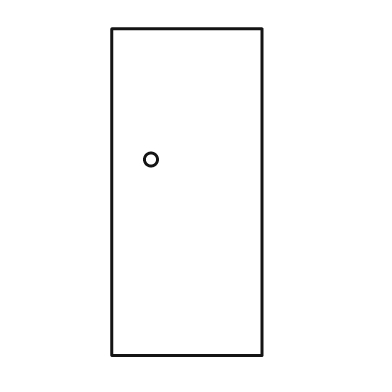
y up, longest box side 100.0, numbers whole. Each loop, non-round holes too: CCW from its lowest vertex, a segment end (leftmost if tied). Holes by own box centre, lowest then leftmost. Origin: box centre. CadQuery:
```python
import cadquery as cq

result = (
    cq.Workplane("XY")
    .moveTo(-23.0, -50.0)
    .lineTo(23.0, -50.0)
    .lineTo(23.0, 50.0)
    .lineTo(-23.0, 50.0)
    .close()
    .moveTo(-11.0, 10.0)
    .circle(2.0)
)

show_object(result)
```